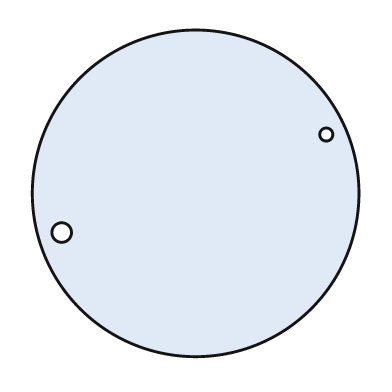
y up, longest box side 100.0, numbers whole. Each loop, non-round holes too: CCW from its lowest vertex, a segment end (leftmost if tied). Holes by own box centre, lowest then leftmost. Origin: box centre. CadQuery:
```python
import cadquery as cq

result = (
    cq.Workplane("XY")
    .moveTo(0.0, 0.0)
    .circle(50.0)
    .moveTo(-41.0, -12.0)
    .circle(3.0)
    .moveTo(40.0, 18.0)
    .circle(2.0)
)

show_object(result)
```